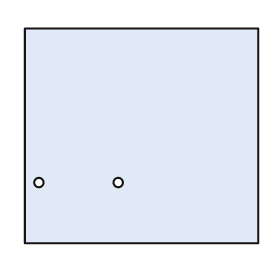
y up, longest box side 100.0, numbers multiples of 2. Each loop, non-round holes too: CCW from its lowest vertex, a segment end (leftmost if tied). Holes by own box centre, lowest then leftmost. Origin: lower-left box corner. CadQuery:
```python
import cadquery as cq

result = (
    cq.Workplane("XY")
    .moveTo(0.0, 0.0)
    .lineTo(100.0, 0.0)
    .lineTo(100.0, 92.0)
    .lineTo(0.0, 92.0)
    .close()
    .moveTo(6.0, 26.0)
    .circle(2.0)
    .moveTo(40.0, 26.0)
    .circle(2.0)
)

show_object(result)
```